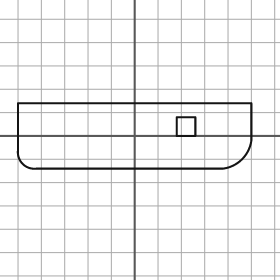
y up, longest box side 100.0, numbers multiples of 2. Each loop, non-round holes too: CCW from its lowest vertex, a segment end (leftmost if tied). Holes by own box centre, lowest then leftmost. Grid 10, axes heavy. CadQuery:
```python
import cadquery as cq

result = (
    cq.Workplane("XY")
    .moveTo(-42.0, -14.0)
    .lineTo(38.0, -14.0)
    .threePointArc((46.0, -10.0), (50.0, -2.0))
    .lineTo(50.0, 14.0)
    .lineTo(-50.0, 14.0)
    .lineTo(-50.0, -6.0)
    .threePointArc((-48.0, -12.0), (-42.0, -14.0))
    .close()
    .moveTo(18.0, 0.0)
    .lineTo(26.0, 0.0)
    .lineTo(26.0, 8.0)
    .lineTo(18.0, 8.0)
    .close()
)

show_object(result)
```